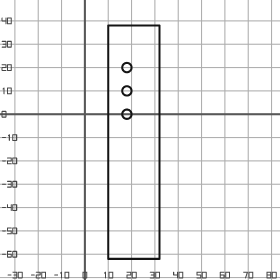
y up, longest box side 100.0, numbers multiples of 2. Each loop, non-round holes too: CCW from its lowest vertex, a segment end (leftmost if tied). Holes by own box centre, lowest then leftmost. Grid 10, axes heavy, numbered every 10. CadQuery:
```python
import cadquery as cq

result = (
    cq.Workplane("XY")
    .moveTo(10.0, -62.0)
    .lineTo(32.0, -62.0)
    .lineTo(32.0, 38.0)
    .lineTo(10.0, 38.0)
    .close()
    .moveTo(18.0, 0.0)
    .circle(2.0)
    .moveTo(18.0, 10.0)
    .circle(2.0)
    .moveTo(18.0, 20.0)
    .circle(2.0)
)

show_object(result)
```